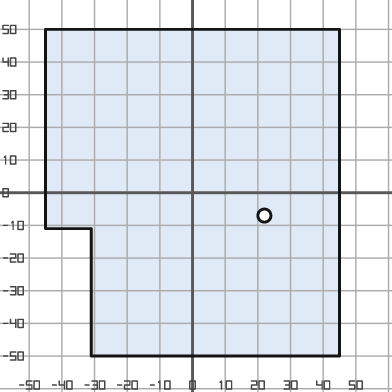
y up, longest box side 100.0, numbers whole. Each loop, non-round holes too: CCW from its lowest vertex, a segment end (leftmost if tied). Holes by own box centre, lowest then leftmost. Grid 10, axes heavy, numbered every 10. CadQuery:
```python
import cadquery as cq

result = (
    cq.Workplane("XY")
    .moveTo(-31.0, -50.0)
    .lineTo(45.0, -50.0)
    .lineTo(45.0, 50.0)
    .lineTo(-45.0, 50.0)
    .lineTo(-45.0, -11.0)
    .lineTo(-31.0, -11.0)
    .close()
    .moveTo(22.0, -7.0)
    .circle(2.0)
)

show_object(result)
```